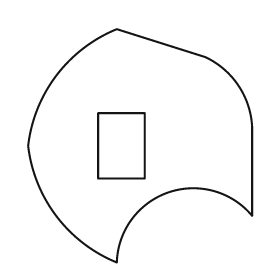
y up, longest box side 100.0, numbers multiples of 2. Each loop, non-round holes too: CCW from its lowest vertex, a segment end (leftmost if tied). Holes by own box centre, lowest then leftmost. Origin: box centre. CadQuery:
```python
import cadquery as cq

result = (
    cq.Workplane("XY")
    .moveTo(-10.0, -50.0)
    .threePointArc((12.0, -20.0), (48.0, -30.0))
    .lineTo(48.0, 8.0)
    .threePointArc((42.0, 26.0), (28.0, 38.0))
    .lineTo(-10.0, 50.0)
    .threePointArc((-36.0, 30.0), (-48.0, 0.0))
    .threePointArc((-36.0, -30.0), (-10.0, -50.0))
    .close()
    .moveTo(-18.0, -14.0)
    .lineTo(2.0, -14.0)
    .lineTo(2.0, 14.0)
    .lineTo(-18.0, 14.0)
    .close()
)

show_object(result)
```